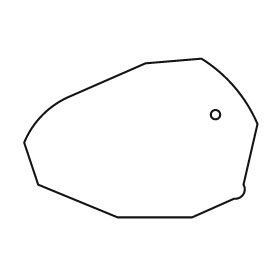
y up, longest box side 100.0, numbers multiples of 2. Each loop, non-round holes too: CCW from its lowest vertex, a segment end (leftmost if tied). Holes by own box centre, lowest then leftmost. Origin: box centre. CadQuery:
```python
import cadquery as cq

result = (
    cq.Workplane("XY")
    .moveTo(-10.0, -34.0)
    .lineTo(22.0, -34.0)
    .lineTo(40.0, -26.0)
    .threePointArc((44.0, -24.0), (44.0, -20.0))
    .lineTo(50.0, 6.0)
    .threePointArc((40.0, 22.0), (26.0, 34.0))
    .lineTo(2.0, 32.0)
    .lineTo(-30.0, 18.0)
    .threePointArc((-42.0, 10.0), (-50.0, -2.0))
    .lineTo(-44.0, -20.0)
    .close()
    .moveTo(32.0, 10.0)
    .circle(2.0)
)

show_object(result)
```